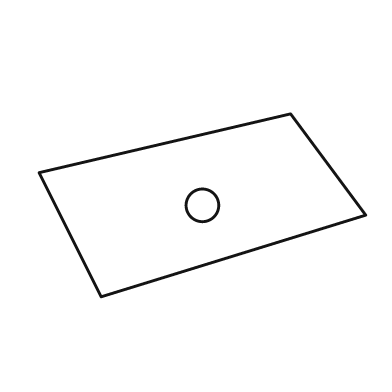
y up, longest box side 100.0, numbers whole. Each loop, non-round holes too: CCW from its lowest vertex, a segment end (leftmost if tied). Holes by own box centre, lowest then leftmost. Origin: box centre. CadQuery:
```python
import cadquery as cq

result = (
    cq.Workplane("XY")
    .moveTo(-31.0, -28.0)
    .lineTo(50.0, -3.0)
    .lineTo(27.0, 28.0)
    .lineTo(-50.0, 10.0)
    .close()
    .moveTo(0.0, 0.0)
    .circle(5.0)
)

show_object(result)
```